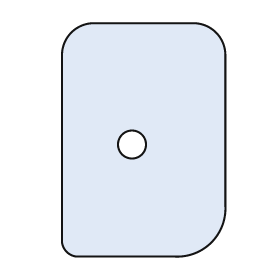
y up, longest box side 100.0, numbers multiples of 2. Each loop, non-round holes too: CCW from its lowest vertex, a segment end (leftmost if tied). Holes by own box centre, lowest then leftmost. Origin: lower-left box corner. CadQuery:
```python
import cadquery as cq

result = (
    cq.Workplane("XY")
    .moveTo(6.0, 0.0)
    .lineTo(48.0, 0.0)
    .threePointArc((64.0, 6.0), (70.0, 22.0))
    .lineTo(70.0, 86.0)
    .threePointArc((66.0, 96.0), (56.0, 100.0))
    .lineTo(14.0, 100.0)
    .threePointArc((4.0, 96.0), (0.0, 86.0))
    .lineTo(0.0, 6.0)
    .threePointArc((2.0, 2.0), (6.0, 0.0))
    .close()
    .moveTo(30.0, 48.0)
    .circle(6.0)
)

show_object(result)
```